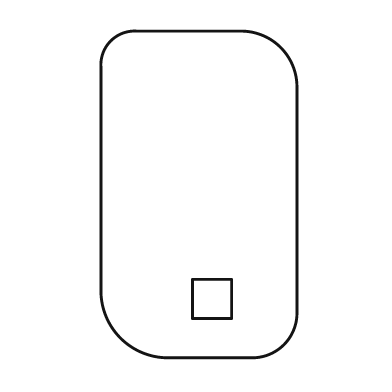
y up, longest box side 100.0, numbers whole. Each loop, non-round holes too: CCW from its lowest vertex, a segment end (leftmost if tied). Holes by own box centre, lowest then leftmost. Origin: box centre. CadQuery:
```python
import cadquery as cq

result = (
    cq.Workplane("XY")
    .moveTo(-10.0, -50.0)
    .lineTo(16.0, -50.0)
    .threePointArc((26.0, -46.0), (30.0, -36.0))
    .lineTo(30.0, 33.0)
    .threePointArc((25.0, 45.0), (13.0, 50.0))
    .lineTo(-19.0, 50.0)
    .threePointArc((-27.0, 47.0), (-30.0, 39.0))
    .lineTo(-30.0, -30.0)
    .threePointArc((-24.0, -44.0), (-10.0, -50.0))
    .close()
    .moveTo(-2.0, -38.0)
    .lineTo(10.0, -38.0)
    .lineTo(10.0, -26.0)
    .lineTo(-2.0, -26.0)
    .close()
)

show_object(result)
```